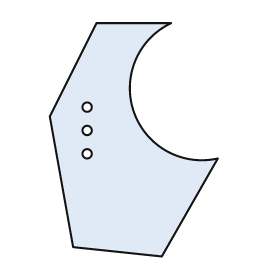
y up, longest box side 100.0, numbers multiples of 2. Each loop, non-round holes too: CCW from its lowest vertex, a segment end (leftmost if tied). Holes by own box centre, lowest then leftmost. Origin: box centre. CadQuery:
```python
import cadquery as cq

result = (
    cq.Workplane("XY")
    .moveTo(12.0, -50.0)
    .lineTo(36.0, -8.0)
    .threePointArc((0.0, 12.0), (16.0, 50.0))
    .lineTo(-16.0, 50.0)
    .lineTo(-36.0, 10.0)
    .lineTo(-26.0, -46.0)
    .close()
    .moveTo(-20.0, -6.0)
    .circle(2.0)
    .moveTo(-20.0, 4.0)
    .circle(2.0)
    .moveTo(-20.0, 14.0)
    .circle(2.0)
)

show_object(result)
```